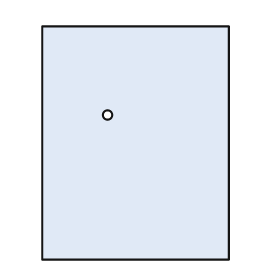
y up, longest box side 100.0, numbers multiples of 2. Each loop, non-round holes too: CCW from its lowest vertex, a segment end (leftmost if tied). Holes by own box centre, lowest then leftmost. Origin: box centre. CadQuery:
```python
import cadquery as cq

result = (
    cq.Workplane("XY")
    .moveTo(-40.0, -50.0)
    .lineTo(40.0, -50.0)
    .lineTo(40.0, 50.0)
    .lineTo(-40.0, 50.0)
    .close()
    .moveTo(-12.0, 12.0)
    .circle(2.0)
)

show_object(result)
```